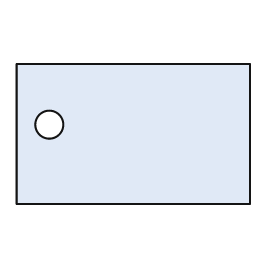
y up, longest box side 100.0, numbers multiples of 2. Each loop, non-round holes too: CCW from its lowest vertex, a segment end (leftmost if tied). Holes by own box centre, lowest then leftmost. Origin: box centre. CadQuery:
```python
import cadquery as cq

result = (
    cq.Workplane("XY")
    .moveTo(-50.0, -30.0)
    .lineTo(50.0, -30.0)
    .lineTo(50.0, 30.0)
    .lineTo(-50.0, 30.0)
    .close()
    .moveTo(-36.0, 4.0)
    .circle(6.0)
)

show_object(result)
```